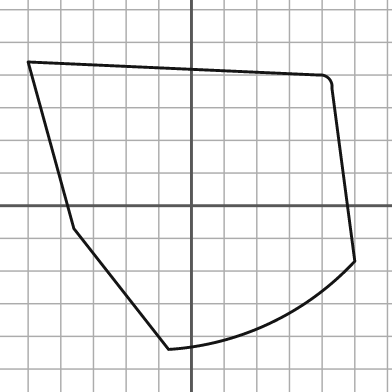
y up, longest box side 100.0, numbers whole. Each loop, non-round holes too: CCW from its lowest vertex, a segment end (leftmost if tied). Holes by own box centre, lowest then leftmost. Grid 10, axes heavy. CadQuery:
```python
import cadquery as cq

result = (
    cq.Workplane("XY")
    .moveTo(-7.0, -44.0)
    .threePointArc((24.0, -36.0), (50.0, -17.0))
    .lineTo(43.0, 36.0)
    .threePointArc((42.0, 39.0), (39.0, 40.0))
    .lineTo(-50.0, 44.0)
    .lineTo(-36.0, -7.0)
    .close()
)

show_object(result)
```